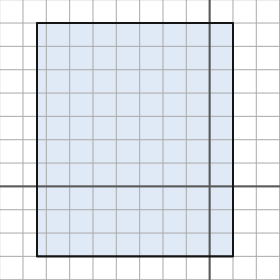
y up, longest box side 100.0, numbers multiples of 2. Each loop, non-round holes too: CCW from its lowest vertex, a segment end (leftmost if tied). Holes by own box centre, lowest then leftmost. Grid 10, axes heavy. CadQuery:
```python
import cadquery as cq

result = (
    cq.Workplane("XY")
    .moveTo(-74.0, -30.0)
    .lineTo(10.0, -30.0)
    .lineTo(10.0, 70.0)
    .lineTo(-74.0, 70.0)
    .close()
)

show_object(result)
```